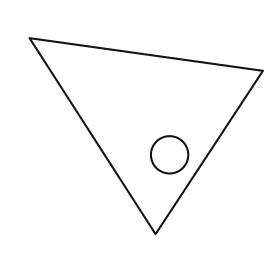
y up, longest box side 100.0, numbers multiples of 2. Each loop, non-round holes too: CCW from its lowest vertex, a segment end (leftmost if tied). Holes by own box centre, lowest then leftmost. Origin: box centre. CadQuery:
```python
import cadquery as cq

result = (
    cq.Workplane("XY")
    .moveTo(4.0, -42.0)
    .lineTo(50.0, 28.0)
    .lineTo(-50.0, 42.0)
    .close()
    .moveTo(10.0, -8.0)
    .circle(8.0)
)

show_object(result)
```